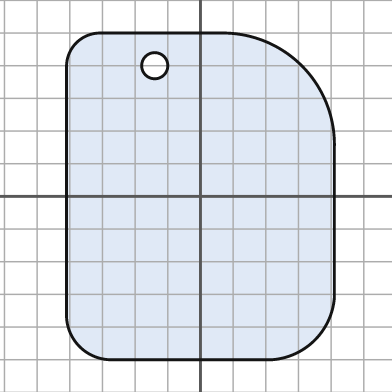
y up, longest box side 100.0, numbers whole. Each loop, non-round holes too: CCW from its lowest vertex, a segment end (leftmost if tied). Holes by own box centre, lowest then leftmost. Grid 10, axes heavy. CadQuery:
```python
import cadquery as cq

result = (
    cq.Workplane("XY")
    .moveTo(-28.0, -50.0)
    .lineTo(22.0, -50.0)
    .threePointArc((35.0, -44.0), (41.0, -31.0))
    .lineTo(41.0, 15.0)
    .threePointArc((31.0, 40.0), (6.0, 50.0))
    .lineTo(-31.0, 50.0)
    .threePointArc((-38.0, 47.0), (-41.0, 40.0))
    .lineTo(-41.0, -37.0)
    .threePointArc((-37.0, -46.0), (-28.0, -50.0))
    .close()
    .moveTo(-14.0, 40.0)
    .circle(4.0)
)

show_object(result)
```